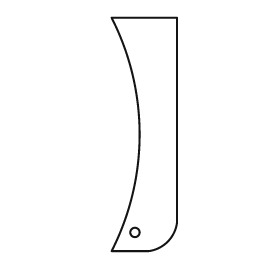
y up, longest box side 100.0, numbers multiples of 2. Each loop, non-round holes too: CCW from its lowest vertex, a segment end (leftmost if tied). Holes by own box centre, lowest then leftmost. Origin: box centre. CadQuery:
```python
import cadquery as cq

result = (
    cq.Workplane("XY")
    .moveTo(-14.0, -50.0)
    .lineTo(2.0, -50.0)
    .threePointArc((10.0, -46.0), (14.0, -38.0))
    .lineTo(14.0, 50.0)
    .lineTo(-14.0, 50.0)
    .threePointArc((-2.0, 0.0), (-14.0, -50.0))
    .close()
    .moveTo(-4.0, -42.0)
    .circle(2.0)
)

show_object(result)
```